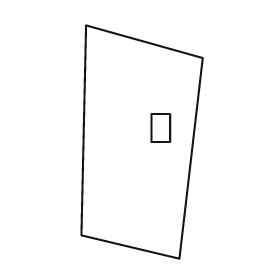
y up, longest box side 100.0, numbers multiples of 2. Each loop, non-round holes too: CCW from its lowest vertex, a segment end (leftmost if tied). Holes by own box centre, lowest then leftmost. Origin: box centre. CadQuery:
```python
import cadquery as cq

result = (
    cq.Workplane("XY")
    .moveTo(16.0, -50.0)
    .lineTo(26.0, 36.0)
    .lineTo(-24.0, 50.0)
    .lineTo(-26.0, -40.0)
    .close()
    .moveTo(4.0, 0.0)
    .lineTo(12.0, 0.0)
    .lineTo(12.0, 12.0)
    .lineTo(4.0, 12.0)
    .close()
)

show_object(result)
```